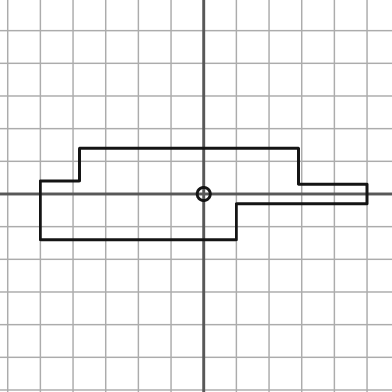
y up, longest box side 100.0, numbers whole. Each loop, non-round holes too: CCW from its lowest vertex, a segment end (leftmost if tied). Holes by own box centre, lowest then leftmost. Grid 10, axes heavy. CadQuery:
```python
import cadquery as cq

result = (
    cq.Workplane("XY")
    .moveTo(-50.0, -14.0)
    .lineTo(10.0, -14.0)
    .lineTo(10.0, -3.0)
    .lineTo(50.0, -3.0)
    .lineTo(50.0, 3.0)
    .lineTo(29.0, 3.0)
    .lineTo(29.0, 14.0)
    .lineTo(-38.0, 14.0)
    .lineTo(-38.0, 4.0)
    .lineTo(-50.0, 4.0)
    .close()
    .moveTo(0.0, 0.0)
    .circle(2.0)
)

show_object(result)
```